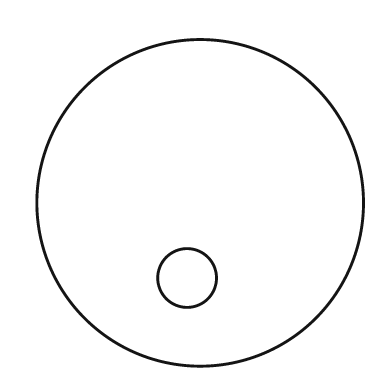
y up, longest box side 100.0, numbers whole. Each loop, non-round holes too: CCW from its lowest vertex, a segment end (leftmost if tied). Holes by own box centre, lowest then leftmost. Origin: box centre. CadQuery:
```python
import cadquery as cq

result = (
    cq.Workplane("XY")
    .moveTo(0.0, 0.0)
    .circle(50.0)
    .moveTo(-4.0, -23.0)
    .circle(9.0)
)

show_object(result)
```